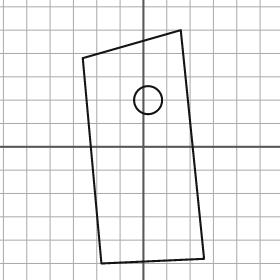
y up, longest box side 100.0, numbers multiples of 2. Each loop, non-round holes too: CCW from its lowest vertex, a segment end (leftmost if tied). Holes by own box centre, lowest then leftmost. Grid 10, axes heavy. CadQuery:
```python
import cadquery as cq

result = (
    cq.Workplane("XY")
    .moveTo(-18.0, -50.0)
    .lineTo(26.0, -48.0)
    .lineTo(16.0, 50.0)
    .lineTo(-26.0, 38.0)
    .close()
    .moveTo(2.0, 20.0)
    .circle(6.0)
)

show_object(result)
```